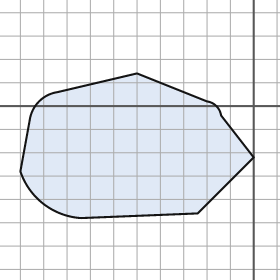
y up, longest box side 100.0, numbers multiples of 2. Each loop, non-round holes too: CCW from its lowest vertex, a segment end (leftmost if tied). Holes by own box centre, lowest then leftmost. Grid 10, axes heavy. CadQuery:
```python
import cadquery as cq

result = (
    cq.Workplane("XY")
    .moveTo(-74.0, -48.0)
    .lineTo(-24.0, -46.0)
    .lineTo(0.0, -22.0)
    .lineTo(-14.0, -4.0)
    .threePointArc((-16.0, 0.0), (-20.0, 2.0))
    .lineTo(-50.0, 14.0)
    .lineTo(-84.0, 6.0)
    .threePointArc((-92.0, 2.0), (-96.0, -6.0))
    .lineTo(-100.0, -28.0)
    .threePointArc((-90.0, -42.0), (-74.0, -48.0))
    .close()
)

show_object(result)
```